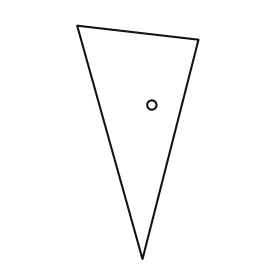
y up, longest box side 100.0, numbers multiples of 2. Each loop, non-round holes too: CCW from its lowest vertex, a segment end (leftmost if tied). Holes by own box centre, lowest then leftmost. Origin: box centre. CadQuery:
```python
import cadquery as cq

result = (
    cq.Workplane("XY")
    .moveTo(2.0, -50.0)
    .lineTo(26.0, 44.0)
    .lineTo(-26.0, 50.0)
    .close()
    .moveTo(6.0, 16.0)
    .circle(2.0)
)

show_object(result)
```